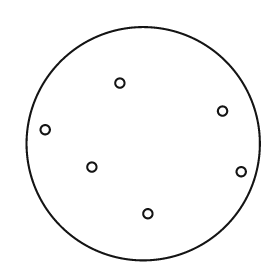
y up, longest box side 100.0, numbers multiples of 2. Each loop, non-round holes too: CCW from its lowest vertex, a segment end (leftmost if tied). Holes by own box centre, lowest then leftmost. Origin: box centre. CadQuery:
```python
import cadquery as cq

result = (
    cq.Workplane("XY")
    .moveTo(0.0, 0.0)
    .circle(50.0)
    .moveTo(2.0, -30.0)
    .circle(2.0)
    .moveTo(42.0, -12.0)
    .circle(2.0)
    .moveTo(-22.0, -10.0)
    .circle(2.0)
    .moveTo(-42.0, 6.0)
    .circle(2.0)
    .moveTo(34.0, 14.0)
    .circle(2.0)
    .moveTo(-10.0, 26.0)
    .circle(2.0)
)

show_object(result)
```